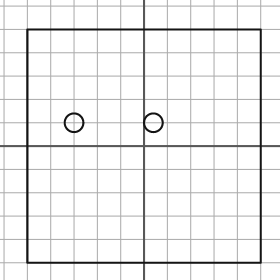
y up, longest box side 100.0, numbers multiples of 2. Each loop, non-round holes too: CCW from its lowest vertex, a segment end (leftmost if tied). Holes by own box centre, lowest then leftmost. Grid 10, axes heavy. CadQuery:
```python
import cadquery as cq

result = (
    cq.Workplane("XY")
    .moveTo(-50.0, -50.0)
    .lineTo(50.0, -50.0)
    .lineTo(50.0, 50.0)
    .lineTo(-50.0, 50.0)
    .close()
    .moveTo(-30.0, 10.0)
    .circle(4.0)
    .moveTo(4.0, 10.0)
    .circle(4.0)
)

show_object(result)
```